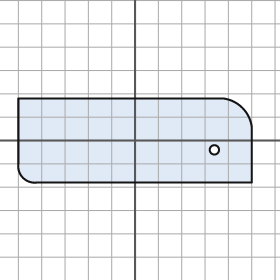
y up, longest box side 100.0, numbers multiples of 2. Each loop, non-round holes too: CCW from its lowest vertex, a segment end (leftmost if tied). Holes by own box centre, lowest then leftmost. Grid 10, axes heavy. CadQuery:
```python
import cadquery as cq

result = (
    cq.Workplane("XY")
    .moveTo(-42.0, -18.0)
    .lineTo(50.0, -18.0)
    .lineTo(50.0, 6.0)
    .threePointArc((46.0, 14.0), (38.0, 18.0))
    .lineTo(-50.0, 18.0)
    .lineTo(-50.0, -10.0)
    .threePointArc((-48.0, -16.0), (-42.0, -18.0))
    .close()
    .moveTo(34.0, -4.0)
    .circle(2.0)
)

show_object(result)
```